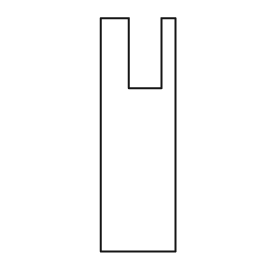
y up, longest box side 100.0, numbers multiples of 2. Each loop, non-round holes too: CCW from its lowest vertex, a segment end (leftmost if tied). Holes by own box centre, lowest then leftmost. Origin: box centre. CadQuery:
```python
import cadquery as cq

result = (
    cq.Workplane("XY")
    .moveTo(-16.0, -50.0)
    .lineTo(16.0, -50.0)
    .lineTo(16.0, 50.0)
    .lineTo(10.0, 50.0)
    .lineTo(10.0, 20.0)
    .lineTo(-4.0, 20.0)
    .lineTo(-4.0, 50.0)
    .lineTo(-16.0, 50.0)
    .close()
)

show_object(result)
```